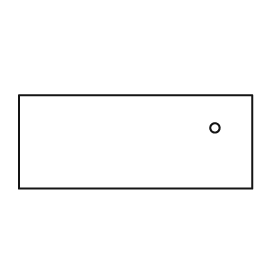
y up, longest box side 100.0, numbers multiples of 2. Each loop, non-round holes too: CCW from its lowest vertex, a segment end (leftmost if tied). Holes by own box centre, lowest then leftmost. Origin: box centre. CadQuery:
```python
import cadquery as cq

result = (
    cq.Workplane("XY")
    .moveTo(-50.0, -20.0)
    .lineTo(50.0, -20.0)
    .lineTo(50.0, 20.0)
    .lineTo(-50.0, 20.0)
    .close()
    .moveTo(34.0, 6.0)
    .circle(2.0)
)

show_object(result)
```